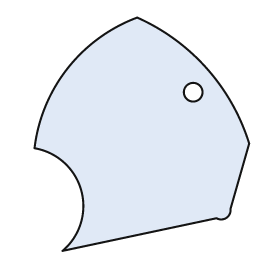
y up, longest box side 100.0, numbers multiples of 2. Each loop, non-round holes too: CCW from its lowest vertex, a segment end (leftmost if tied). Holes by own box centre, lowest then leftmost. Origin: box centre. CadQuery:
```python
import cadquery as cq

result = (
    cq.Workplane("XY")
    .moveTo(-34.0, -50.0)
    .lineTo(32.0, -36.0)
    .threePointArc((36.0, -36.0), (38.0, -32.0))
    .lineTo(46.0, -4.0)
    .threePointArc((28.0, 28.0), (-2.0, 50.0))
    .threePointArc((-32.0, 28.0), (-46.0, -6.0))
    .threePointArc((-26.0, -24.0), (-34.0, -50.0))
    .close()
    .moveTo(22.0, 18.0)
    .circle(4.0)
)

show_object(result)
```